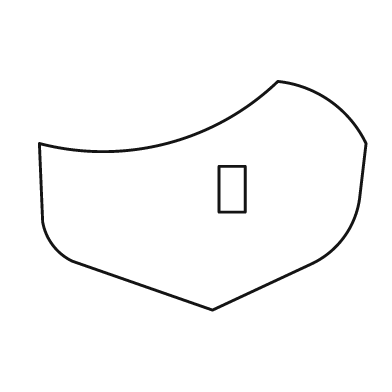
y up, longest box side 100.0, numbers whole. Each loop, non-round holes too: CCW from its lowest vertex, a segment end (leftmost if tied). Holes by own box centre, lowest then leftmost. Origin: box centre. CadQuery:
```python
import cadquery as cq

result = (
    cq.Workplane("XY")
    .moveTo(3.0, -35.0)
    .lineTo(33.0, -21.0)
    .threePointArc((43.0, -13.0), (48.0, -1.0))
    .lineTo(50.0, 16.0)
    .threePointArc((39.0, 29.0), (23.0, 35.0))
    .threePointArc((-11.0, 16.0), (-50.0, 16.0))
    .lineTo(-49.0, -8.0)
    .threePointArc((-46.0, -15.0), (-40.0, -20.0))
    .close()
    .moveTo(5.0, -5.0)
    .lineTo(13.0, -5.0)
    .lineTo(13.0, 9.0)
    .lineTo(5.0, 9.0)
    .close()
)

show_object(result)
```